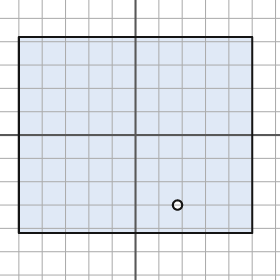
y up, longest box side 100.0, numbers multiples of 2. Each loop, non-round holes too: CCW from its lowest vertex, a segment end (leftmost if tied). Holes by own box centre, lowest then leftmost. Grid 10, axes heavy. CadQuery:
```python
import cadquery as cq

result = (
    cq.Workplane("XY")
    .moveTo(-50.0, -42.0)
    .lineTo(50.0, -42.0)
    .lineTo(50.0, 42.0)
    .lineTo(-50.0, 42.0)
    .close()
    .moveTo(18.0, -30.0)
    .circle(2.0)
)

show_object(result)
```